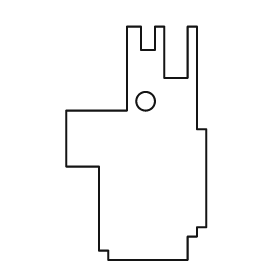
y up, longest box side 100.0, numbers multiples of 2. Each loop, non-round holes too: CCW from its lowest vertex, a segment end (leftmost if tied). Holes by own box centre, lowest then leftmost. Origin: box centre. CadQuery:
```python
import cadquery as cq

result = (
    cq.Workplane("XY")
    .moveTo(-12.0, -50.0)
    .lineTo(22.0, -50.0)
    .lineTo(22.0, -40.0)
    .lineTo(26.0, -40.0)
    .lineTo(26.0, -36.0)
    .lineTo(30.0, -36.0)
    .lineTo(30.0, 6.0)
    .lineTo(26.0, 6.0)
    .lineTo(26.0, 50.0)
    .lineTo(22.0, 50.0)
    .lineTo(22.0, 28.0)
    .lineTo(12.0, 28.0)
    .lineTo(12.0, 50.0)
    .lineTo(8.0, 50.0)
    .lineTo(8.0, 40.0)
    .lineTo(2.0, 40.0)
    .lineTo(2.0, 50.0)
    .lineTo(-4.0, 50.0)
    .lineTo(-4.0, 14.0)
    .lineTo(-30.0, 14.0)
    .lineTo(-30.0, -10.0)
    .lineTo(-16.0, -10.0)
    .lineTo(-16.0, -46.0)
    .lineTo(-12.0, -46.0)
    .close()
    .moveTo(4.0, 18.0)
    .circle(4.0)
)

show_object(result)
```